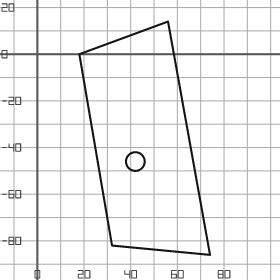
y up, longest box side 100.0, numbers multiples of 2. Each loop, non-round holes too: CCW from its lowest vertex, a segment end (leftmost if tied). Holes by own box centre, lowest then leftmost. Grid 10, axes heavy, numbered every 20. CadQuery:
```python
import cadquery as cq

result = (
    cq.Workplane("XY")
    .moveTo(74.0, -86.0)
    .lineTo(56.0, 14.0)
    .lineTo(18.0, 0.0)
    .lineTo(32.0, -82.0)
    .close()
    .moveTo(42.0, -46.0)
    .circle(4.0)
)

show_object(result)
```